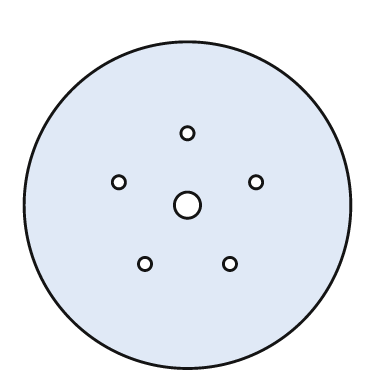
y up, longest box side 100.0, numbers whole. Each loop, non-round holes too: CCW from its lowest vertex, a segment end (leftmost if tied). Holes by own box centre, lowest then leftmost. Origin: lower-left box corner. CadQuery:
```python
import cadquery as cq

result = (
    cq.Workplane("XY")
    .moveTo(50.0, 50.0)
    .circle(50.0)
    .moveTo(37.0, 32.0)
    .circle(2.0)
    .moveTo(63.0, 32.0)
    .circle(2.0)
    .moveTo(50.0, 50.0)
    .circle(4.0)
    .moveTo(29.0, 57.0)
    .circle(2.0)
    .moveTo(71.0, 57.0)
    .circle(2.0)
    .moveTo(50.0, 72.0)
    .circle(2.0)
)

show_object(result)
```